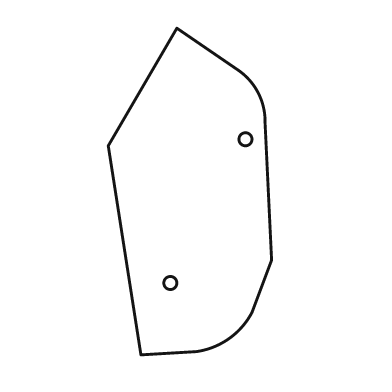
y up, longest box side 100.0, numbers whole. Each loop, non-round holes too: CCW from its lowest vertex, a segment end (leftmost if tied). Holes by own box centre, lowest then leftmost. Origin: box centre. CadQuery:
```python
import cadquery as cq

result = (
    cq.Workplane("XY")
    .moveTo(-15.0, -50.0)
    .lineTo(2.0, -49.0)
    .threePointArc((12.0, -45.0), (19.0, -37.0))
    .lineTo(25.0, -21.0)
    .lineTo(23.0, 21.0)
    .threePointArc((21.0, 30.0), (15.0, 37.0))
    .lineTo(-4.0, 50.0)
    .lineTo(-25.0, 14.0)
    .close()
    .moveTo(-6.0, -28.0)
    .circle(2.0)
    .moveTo(17.0, 16.0)
    .circle(2.0)
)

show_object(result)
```